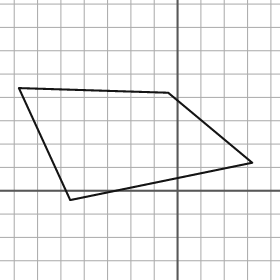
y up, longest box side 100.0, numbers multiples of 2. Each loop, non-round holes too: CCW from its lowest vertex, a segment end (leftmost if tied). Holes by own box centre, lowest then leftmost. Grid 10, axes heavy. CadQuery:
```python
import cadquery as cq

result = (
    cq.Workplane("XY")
    .moveTo(-46.0, -4.0)
    .lineTo(32.0, 12.0)
    .lineTo(-4.0, 42.0)
    .lineTo(-68.0, 44.0)
    .close()
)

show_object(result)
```